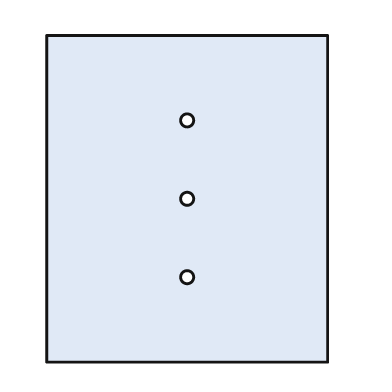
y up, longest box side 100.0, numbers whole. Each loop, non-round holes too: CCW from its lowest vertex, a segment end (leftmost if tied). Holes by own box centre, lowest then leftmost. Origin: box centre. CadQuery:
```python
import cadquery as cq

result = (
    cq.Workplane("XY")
    .moveTo(-43.0, -50.0)
    .lineTo(43.0, -50.0)
    .lineTo(43.0, 50.0)
    .lineTo(-43.0, 50.0)
    .close()
    .moveTo(0.0, -24.0)
    .circle(2.0)
    .moveTo(0.0, 0.0)
    .circle(2.0)
    .moveTo(0.0, 24.0)
    .circle(2.0)
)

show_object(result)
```